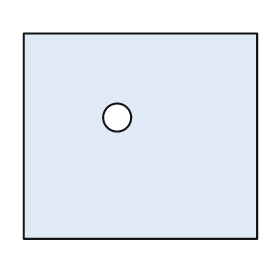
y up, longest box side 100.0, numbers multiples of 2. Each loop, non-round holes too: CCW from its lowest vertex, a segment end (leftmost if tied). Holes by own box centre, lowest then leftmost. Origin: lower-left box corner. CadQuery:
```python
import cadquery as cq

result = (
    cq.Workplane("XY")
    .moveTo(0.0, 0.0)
    .lineTo(100.0, 0.0)
    .lineTo(100.0, 88.0)
    .lineTo(0.0, 88.0)
    .close()
    .moveTo(40.0, 52.0)
    .circle(6.0)
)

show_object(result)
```